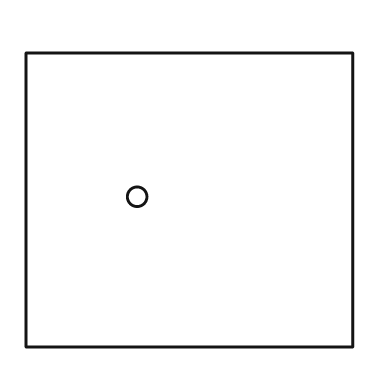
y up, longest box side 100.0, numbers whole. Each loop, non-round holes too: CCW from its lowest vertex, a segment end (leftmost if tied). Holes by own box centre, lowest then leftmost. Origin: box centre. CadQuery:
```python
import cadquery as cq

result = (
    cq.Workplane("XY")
    .moveTo(-50.0, -45.0)
    .lineTo(50.0, -45.0)
    .lineTo(50.0, 45.0)
    .lineTo(-50.0, 45.0)
    .close()
    .moveTo(-16.0, 1.0)
    .circle(3.0)
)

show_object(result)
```